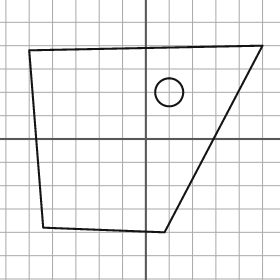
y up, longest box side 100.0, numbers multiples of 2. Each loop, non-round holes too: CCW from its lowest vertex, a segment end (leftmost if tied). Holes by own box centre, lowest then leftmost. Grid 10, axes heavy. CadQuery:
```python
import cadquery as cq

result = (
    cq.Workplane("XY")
    .moveTo(8.0, -40.0)
    .lineTo(50.0, 40.0)
    .lineTo(-50.0, 38.0)
    .lineTo(-44.0, -38.0)
    .close()
    .moveTo(10.0, 20.0)
    .circle(6.0)
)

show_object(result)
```